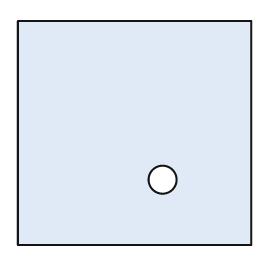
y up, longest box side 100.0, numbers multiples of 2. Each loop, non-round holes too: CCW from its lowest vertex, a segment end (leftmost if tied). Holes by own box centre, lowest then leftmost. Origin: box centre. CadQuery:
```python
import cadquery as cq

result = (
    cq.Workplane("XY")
    .moveTo(-50.0, -48.0)
    .lineTo(50.0, -48.0)
    .lineTo(50.0, 48.0)
    .lineTo(-50.0, 48.0)
    .close()
    .moveTo(12.0, -20.0)
    .circle(6.0)
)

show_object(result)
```